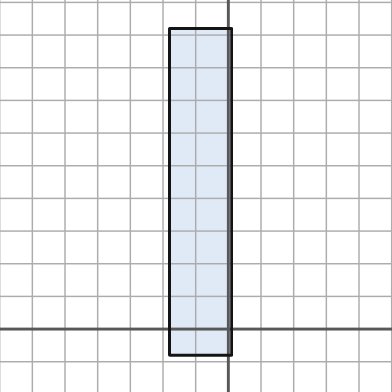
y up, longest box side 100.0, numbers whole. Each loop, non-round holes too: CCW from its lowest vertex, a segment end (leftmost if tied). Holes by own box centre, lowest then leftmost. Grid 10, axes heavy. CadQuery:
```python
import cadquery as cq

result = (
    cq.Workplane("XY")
    .moveTo(-18.0, -8.0)
    .lineTo(1.0, -8.0)
    .lineTo(1.0, 92.0)
    .lineTo(-18.0, 92.0)
    .close()
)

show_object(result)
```